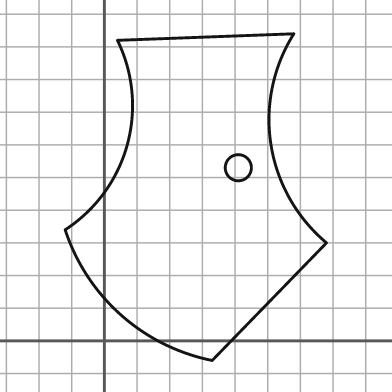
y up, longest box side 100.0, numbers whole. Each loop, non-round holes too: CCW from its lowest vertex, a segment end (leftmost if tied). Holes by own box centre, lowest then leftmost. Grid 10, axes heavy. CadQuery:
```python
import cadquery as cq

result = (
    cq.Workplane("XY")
    .moveTo(33.0, -6.0)
    .lineTo(68.0, 30.0)
    .threePointArc((51.0, 60.0), (58.0, 94.0))
    .lineTo(4.0, 92.0)
    .threePointArc((7.0, 60.0), (-12.0, 34.0))
    .threePointArc((5.0, 8.0), (33.0, -6.0))
    .close()
    .moveTo(41.0, 53.0)
    .circle(4.0)
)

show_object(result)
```